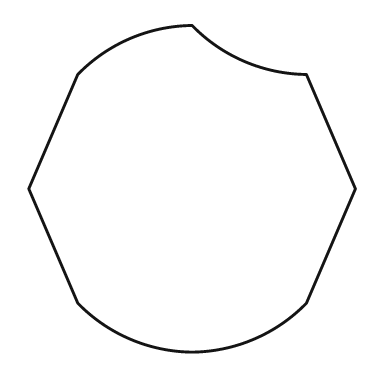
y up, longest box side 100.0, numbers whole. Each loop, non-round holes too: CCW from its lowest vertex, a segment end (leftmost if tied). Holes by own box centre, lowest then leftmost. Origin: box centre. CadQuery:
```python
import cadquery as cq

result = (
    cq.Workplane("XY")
    .moveTo(0.0, -50.0)
    .threePointArc((19.0, -46.0), (35.0, -35.0))
    .lineTo(50.0, 0.0)
    .lineTo(35.0, 35.0)
    .threePointArc((16.0, 39.0), (0.0, 50.0))
    .threePointArc((-19.0, 46.0), (-35.0, 35.0))
    .lineTo(-50.0, 0.0)
    .lineTo(-35.0, -35.0)
    .threePointArc((-19.0, -46.0), (0.0, -50.0))
    .close()
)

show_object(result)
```